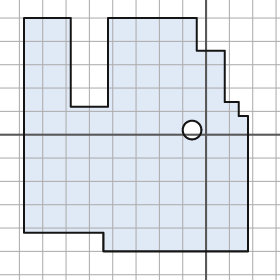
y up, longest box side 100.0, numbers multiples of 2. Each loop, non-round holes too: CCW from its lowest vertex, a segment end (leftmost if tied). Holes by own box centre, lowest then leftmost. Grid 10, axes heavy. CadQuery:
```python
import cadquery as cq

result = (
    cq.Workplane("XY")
    .moveTo(-44.0, -50.0)
    .lineTo(18.0, -50.0)
    .lineTo(18.0, 8.0)
    .lineTo(14.0, 8.0)
    .lineTo(14.0, 14.0)
    .lineTo(8.0, 14.0)
    .lineTo(8.0, 36.0)
    .lineTo(-4.0, 36.0)
    .lineTo(-4.0, 50.0)
    .lineTo(-42.0, 50.0)
    .lineTo(-42.0, 12.0)
    .lineTo(-58.0, 12.0)
    .lineTo(-58.0, 50.0)
    .lineTo(-78.0, 50.0)
    .lineTo(-78.0, -42.0)
    .lineTo(-44.0, -42.0)
    .close()
    .moveTo(-6.0, 2.0)
    .circle(4.0)
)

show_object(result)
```